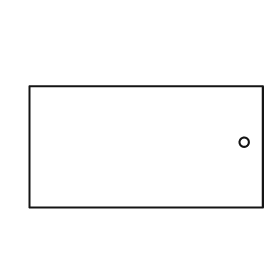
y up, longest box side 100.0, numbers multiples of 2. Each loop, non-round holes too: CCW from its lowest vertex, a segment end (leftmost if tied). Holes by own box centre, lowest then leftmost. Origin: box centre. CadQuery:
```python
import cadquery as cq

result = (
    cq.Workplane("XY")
    .moveTo(-50.0, -26.0)
    .lineTo(50.0, -26.0)
    .lineTo(50.0, 26.0)
    .lineTo(-50.0, 26.0)
    .close()
    .moveTo(42.0, 2.0)
    .circle(2.0)
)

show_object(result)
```